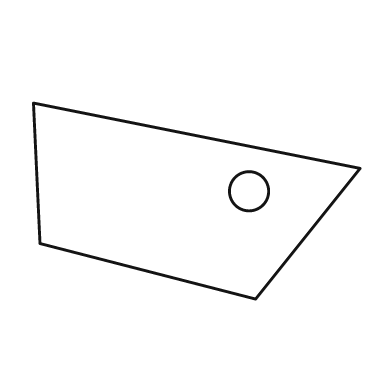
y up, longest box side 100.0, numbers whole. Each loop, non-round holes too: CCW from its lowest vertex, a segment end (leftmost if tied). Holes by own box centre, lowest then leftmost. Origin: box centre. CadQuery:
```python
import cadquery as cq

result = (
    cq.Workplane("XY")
    .moveTo(18.0, -30.0)
    .lineTo(50.0, 10.0)
    .lineTo(-50.0, 30.0)
    .lineTo(-48.0, -13.0)
    .close()
    .moveTo(16.0, 3.0)
    .circle(6.0)
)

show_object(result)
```